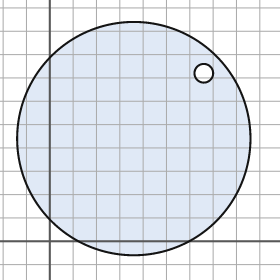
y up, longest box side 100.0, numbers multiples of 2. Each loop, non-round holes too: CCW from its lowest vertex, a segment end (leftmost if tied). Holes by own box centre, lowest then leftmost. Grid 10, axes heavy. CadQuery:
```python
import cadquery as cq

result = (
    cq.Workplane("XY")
    .moveTo(36.0, 44.0)
    .circle(50.0)
    .moveTo(66.0, 72.0)
    .circle(4.0)
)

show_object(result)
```